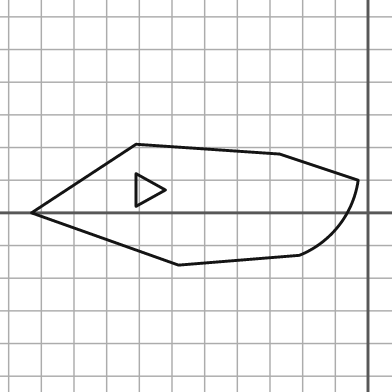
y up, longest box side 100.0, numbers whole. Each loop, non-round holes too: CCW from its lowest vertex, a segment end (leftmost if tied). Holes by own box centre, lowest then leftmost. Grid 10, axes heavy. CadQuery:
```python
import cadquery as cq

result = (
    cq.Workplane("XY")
    .moveTo(-58.0, -16.0)
    .lineTo(-21.0, -13.0)
    .threePointArc((-9.0, -4.0), (-3.0, 10.0))
    .lineTo(-27.0, 18.0)
    .lineTo(-71.0, 21.0)
    .lineTo(-103.0, 0.0)
    .close()
    .moveTo(-71.0, 2.0)
    .lineTo(-62.0, 7.0)
    .lineTo(-71.0, 12.0)
    .close()
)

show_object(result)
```